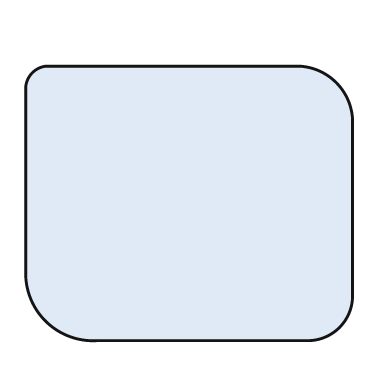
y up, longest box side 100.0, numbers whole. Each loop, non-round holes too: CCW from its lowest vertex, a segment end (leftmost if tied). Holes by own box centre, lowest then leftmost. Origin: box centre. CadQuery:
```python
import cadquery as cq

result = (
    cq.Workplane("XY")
    .moveTo(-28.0, -42.0)
    .lineTo(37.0, -42.0)
    .threePointArc((46.0, -38.0), (50.0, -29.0))
    .lineTo(50.0, 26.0)
    .threePointArc((45.0, 37.0), (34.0, 42.0))
    .lineTo(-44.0, 42.0)
    .threePointArc((-48.0, 40.0), (-50.0, 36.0))
    .lineTo(-50.0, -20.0)
    .threePointArc((-44.0, -36.0), (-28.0, -42.0))
    .close()
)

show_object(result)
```